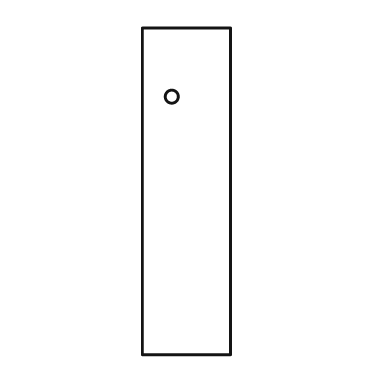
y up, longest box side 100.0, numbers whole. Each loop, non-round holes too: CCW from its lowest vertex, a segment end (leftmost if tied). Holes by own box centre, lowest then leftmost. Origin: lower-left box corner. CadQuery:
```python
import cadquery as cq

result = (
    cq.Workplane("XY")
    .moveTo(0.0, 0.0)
    .lineTo(27.0, 0.0)
    .lineTo(27.0, 100.0)
    .lineTo(0.0, 100.0)
    .close()
    .moveTo(9.0, 79.0)
    .circle(2.0)
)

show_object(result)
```